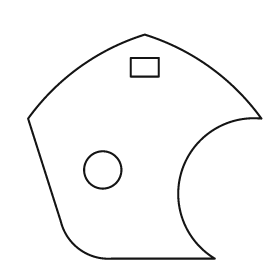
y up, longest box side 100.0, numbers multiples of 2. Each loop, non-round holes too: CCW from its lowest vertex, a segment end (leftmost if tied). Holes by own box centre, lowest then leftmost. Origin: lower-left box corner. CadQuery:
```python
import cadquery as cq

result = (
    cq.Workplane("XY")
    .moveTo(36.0, 0.0)
    .lineTo(80.0, 0.0)
    .threePointArc((66.0, 38.0), (100.0, 60.0))
    .threePointArc((78.0, 82.0), (50.0, 96.0))
    .threePointArc((22.0, 82.0), (0.0, 60.0))
    .lineTo(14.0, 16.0)
    .threePointArc((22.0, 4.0), (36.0, 0.0))
    .close()
    .moveTo(32.0, 38.0)
    .circle(8.0)
    .moveTo(44.0, 78.0)
    .lineTo(56.0, 78.0)
    .lineTo(56.0, 86.0)
    .lineTo(44.0, 86.0)
    .close()
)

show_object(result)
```